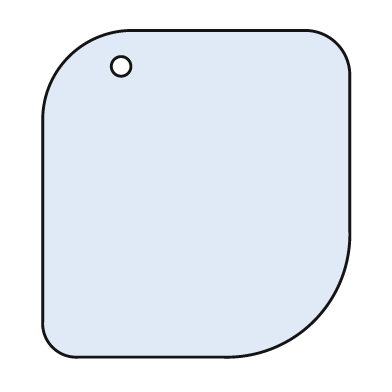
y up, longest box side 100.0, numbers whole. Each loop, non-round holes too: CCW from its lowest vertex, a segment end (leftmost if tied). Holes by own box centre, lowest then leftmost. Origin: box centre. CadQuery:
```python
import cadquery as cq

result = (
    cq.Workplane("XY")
    .moveTo(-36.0, -50.0)
    .lineTo(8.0, -50.0)
    .threePointArc((36.0, -39.0), (47.0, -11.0))
    .lineTo(47.0, 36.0)
    .threePointArc((43.0, 46.0), (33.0, 50.0))
    .lineTo(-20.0, 50.0)
    .threePointArc((-39.0, 42.0), (-47.0, 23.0))
    .lineTo(-47.0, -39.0)
    .threePointArc((-44.0, -47.0), (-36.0, -50.0))
    .close()
    .moveTo(-23.0, 39.0)
    .circle(3.0)
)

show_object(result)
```